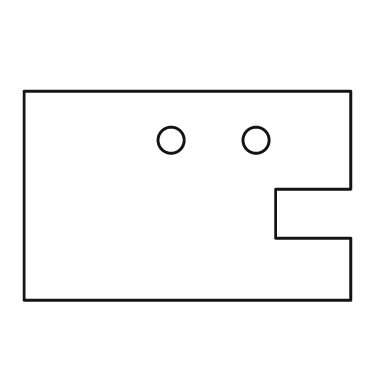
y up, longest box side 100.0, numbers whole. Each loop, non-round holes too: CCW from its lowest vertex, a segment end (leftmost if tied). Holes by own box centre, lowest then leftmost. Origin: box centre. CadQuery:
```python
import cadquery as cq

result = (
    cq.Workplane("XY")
    .moveTo(-50.0, -32.0)
    .lineTo(50.0, -32.0)
    .lineTo(50.0, -13.0)
    .lineTo(27.0, -13.0)
    .lineTo(27.0, 2.0)
    .lineTo(50.0, 2.0)
    .lineTo(50.0, 32.0)
    .lineTo(-50.0, 32.0)
    .close()
    .moveTo(-5.0, 17.0)
    .circle(4.0)
    .moveTo(21.0, 17.0)
    .circle(4.0)
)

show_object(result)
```